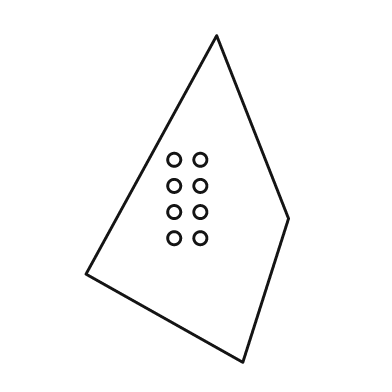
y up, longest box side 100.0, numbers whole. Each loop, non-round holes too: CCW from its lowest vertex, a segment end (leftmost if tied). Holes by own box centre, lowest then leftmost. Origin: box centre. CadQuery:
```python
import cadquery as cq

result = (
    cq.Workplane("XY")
    .moveTo(17.0, -50.0)
    .lineTo(31.0, -6.0)
    .lineTo(9.0, 50.0)
    .lineTo(-31.0, -23.0)
    .close()
    .moveTo(-4.0, -12.0)
    .circle(2.0)
    .moveTo(4.0, -12.0)
    .circle(2.0)
    .moveTo(-4.0, -4.0)
    .circle(2.0)
    .moveTo(4.0, -4.0)
    .circle(2.0)
    .moveTo(-4.0, 4.0)
    .circle(2.0)
    .moveTo(4.0, 4.0)
    .circle(2.0)
    .moveTo(-4.0, 12.0)
    .circle(2.0)
    .moveTo(4.0, 12.0)
    .circle(2.0)
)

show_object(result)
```